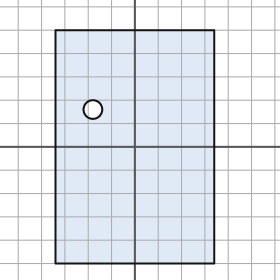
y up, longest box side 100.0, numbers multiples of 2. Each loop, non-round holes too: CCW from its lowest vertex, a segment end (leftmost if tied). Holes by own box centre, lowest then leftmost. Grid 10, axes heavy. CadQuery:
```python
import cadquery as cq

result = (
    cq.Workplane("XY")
    .moveTo(-34.0, -50.0)
    .lineTo(34.0, -50.0)
    .lineTo(34.0, 50.0)
    .lineTo(-34.0, 50.0)
    .close()
    .moveTo(-18.0, 16.0)
    .circle(4.0)
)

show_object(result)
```